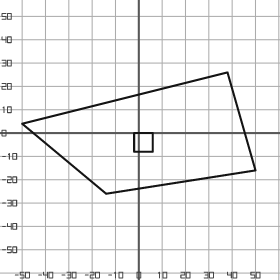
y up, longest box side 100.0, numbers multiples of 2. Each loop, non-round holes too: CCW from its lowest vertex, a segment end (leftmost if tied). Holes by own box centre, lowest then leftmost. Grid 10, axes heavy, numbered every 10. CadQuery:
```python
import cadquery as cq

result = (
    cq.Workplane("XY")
    .moveTo(-14.0, -26.0)
    .lineTo(50.0, -16.0)
    .lineTo(38.0, 26.0)
    .lineTo(-50.0, 4.0)
    .close()
    .moveTo(-2.0, -8.0)
    .lineTo(6.0, -8.0)
    .lineTo(6.0, 0.0)
    .lineTo(-2.0, 0.0)
    .close()
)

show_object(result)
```